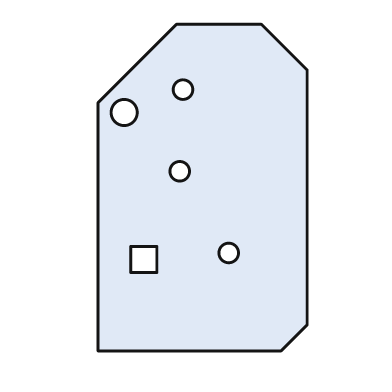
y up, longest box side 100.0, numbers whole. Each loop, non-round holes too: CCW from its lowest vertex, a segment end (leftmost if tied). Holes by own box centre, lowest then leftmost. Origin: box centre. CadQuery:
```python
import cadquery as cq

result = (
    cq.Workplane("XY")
    .moveTo(-32.0, -50.0)
    .lineTo(24.0, -50.0)
    .lineTo(32.0, -42.0)
    .lineTo(32.0, 36.0)
    .lineTo(18.0, 50.0)
    .lineTo(-8.0, 50.0)
    .lineTo(-32.0, 26.0)
    .close()
    .moveTo(-22.0, -26.0)
    .lineTo(-14.0, -26.0)
    .lineTo(-14.0, -18.0)
    .lineTo(-22.0, -18.0)
    .close()
    .moveTo(8.0, -20.0)
    .circle(3.0)
    .moveTo(-7.0, 5.0)
    .circle(3.0)
    .moveTo(-24.0, 23.0)
    .circle(4.0)
    .moveTo(-6.0, 30.0)
    .circle(3.0)
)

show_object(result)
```